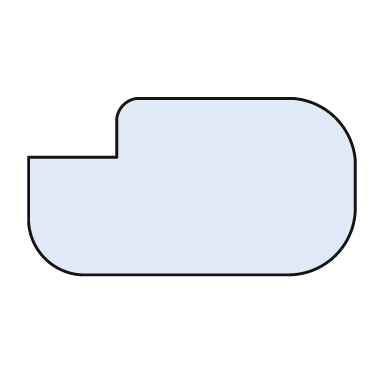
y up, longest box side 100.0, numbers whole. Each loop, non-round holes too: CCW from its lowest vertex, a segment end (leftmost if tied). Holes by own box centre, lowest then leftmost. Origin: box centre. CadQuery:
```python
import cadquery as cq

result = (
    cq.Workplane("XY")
    .moveTo(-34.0, -27.0)
    .lineTo(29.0, -27.0)
    .threePointArc((44.0, -21.0), (50.0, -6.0))
    .lineTo(50.0, 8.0)
    .threePointArc((44.0, 21.0), (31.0, 27.0))
    .lineTo(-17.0, 27.0)
    .threePointArc((-21.0, 25.0), (-23.0, 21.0))
    .lineTo(-23.0, 9.0)
    .lineTo(-50.0, 9.0)
    .lineTo(-50.0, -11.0)
    .threePointArc((-45.0, -22.0), (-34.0, -27.0))
    .close()
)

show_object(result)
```